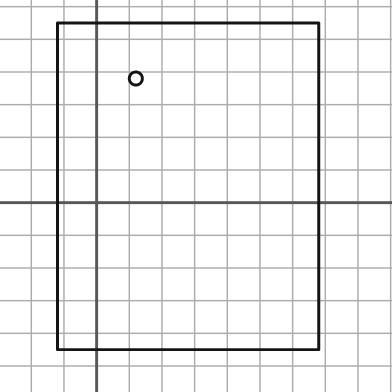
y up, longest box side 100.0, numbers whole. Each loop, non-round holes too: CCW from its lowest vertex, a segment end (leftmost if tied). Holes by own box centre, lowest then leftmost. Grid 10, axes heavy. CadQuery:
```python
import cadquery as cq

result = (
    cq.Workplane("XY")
    .moveTo(-12.0, -45.0)
    .lineTo(68.0, -45.0)
    .lineTo(68.0, 55.0)
    .lineTo(-12.0, 55.0)
    .close()
    .moveTo(12.0, 38.0)
    .circle(2.0)
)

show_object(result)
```